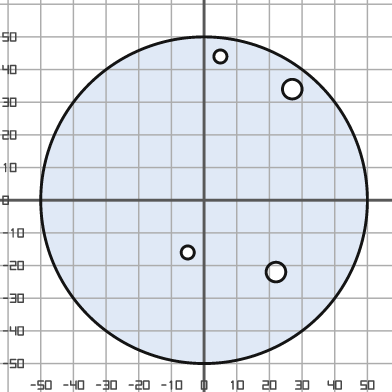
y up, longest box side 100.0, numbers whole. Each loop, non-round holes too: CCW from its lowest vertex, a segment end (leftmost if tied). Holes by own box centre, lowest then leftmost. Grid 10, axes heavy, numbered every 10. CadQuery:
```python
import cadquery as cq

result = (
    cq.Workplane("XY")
    .moveTo(0.0, 0.0)
    .circle(50.0)
    .moveTo(22.0, -22.0)
    .circle(3.0)
    .moveTo(-5.0, -16.0)
    .circle(2.0)
    .moveTo(27.0, 34.0)
    .circle(3.0)
    .moveTo(5.0, 44.0)
    .circle(2.0)
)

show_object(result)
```